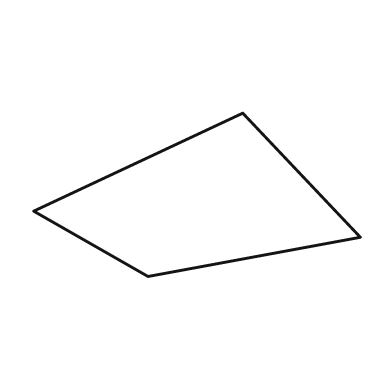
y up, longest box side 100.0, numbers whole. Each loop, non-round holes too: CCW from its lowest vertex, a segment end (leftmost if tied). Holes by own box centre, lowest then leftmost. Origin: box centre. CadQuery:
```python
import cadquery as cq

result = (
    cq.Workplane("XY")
    .moveTo(-15.0, -25.0)
    .lineTo(50.0, -13.0)
    .lineTo(14.0, 25.0)
    .lineTo(-50.0, -5.0)
    .close()
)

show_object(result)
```